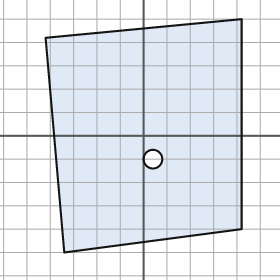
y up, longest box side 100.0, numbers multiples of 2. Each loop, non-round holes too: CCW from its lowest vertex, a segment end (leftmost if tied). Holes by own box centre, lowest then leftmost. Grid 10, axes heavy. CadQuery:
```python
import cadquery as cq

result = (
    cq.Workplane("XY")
    .moveTo(-34.0, -50.0)
    .lineTo(42.0, -40.0)
    .lineTo(42.0, 50.0)
    .lineTo(-42.0, 42.0)
    .close()
    .moveTo(4.0, -10.0)
    .circle(4.0)
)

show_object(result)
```